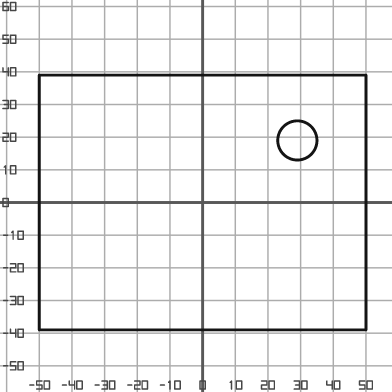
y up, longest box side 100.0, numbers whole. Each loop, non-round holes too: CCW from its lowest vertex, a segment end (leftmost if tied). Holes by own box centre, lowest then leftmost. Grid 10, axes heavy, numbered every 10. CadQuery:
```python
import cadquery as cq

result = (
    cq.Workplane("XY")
    .moveTo(-50.0, -39.0)
    .lineTo(50.0, -39.0)
    .lineTo(50.0, 39.0)
    .lineTo(-50.0, 39.0)
    .close()
    .moveTo(29.0, 19.0)
    .circle(6.0)
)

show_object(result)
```